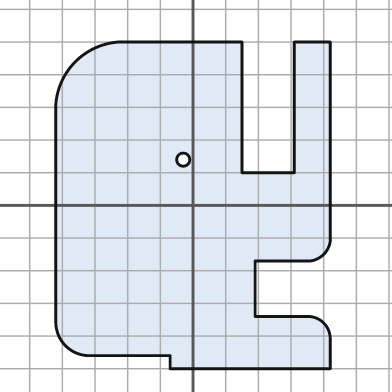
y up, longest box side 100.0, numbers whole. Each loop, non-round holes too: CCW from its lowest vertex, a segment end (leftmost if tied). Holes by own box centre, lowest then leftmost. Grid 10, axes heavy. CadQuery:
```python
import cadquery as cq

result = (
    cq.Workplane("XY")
    .moveTo(-7.0, -50.0)
    .lineTo(42.0, -50.0)
    .lineTo(42.0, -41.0)
    .threePointArc((40.0, -36.0), (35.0, -34.0))
    .lineTo(19.0, -34.0)
    .lineTo(19.0, -17.0)
    .lineTo(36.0, -17.0)
    .threePointArc((40.0, -15.0), (42.0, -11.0))
    .lineTo(42.0, 50.0)
    .lineTo(31.0, 50.0)
    .lineTo(31.0, 10.0)
    .lineTo(15.0, 10.0)
    .lineTo(15.0, 50.0)
    .lineTo(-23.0, 50.0)
    .threePointArc((-36.0, 44.0), (-42.0, 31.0))
    .lineTo(-42.0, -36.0)
    .threePointArc((-39.0, -43.0), (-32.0, -46.0))
    .lineTo(-7.0, -46.0)
    .close()
    .moveTo(-3.0, 14.0)
    .circle(2.0)
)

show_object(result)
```